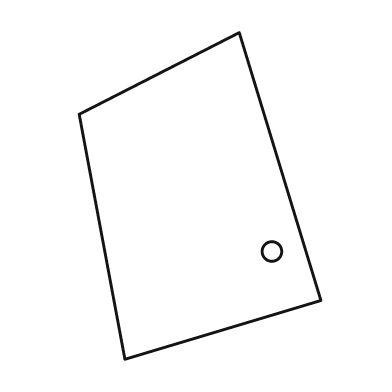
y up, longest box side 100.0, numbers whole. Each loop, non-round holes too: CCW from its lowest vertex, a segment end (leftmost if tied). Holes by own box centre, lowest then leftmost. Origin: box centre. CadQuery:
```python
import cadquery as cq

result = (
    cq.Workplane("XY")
    .moveTo(-23.0, -50.0)
    .lineTo(37.0, -32.0)
    .lineTo(12.0, 50.0)
    .lineTo(-37.0, 25.0)
    .close()
    .moveTo(22.0, -17.0)
    .circle(3.0)
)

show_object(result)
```